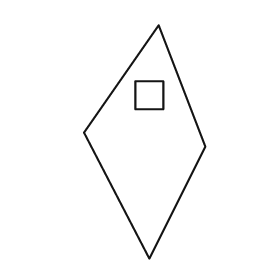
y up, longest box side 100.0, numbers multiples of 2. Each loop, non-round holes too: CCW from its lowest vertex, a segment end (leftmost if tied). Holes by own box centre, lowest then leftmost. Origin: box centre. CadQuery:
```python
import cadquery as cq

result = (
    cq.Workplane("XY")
    .moveTo(2.0, -50.0)
    .lineTo(26.0, -2.0)
    .lineTo(6.0, 50.0)
    .lineTo(-26.0, 4.0)
    .close()
    .moveTo(-4.0, 14.0)
    .lineTo(8.0, 14.0)
    .lineTo(8.0, 26.0)
    .lineTo(-4.0, 26.0)
    .close()
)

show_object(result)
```